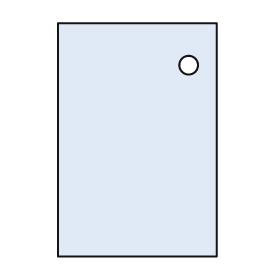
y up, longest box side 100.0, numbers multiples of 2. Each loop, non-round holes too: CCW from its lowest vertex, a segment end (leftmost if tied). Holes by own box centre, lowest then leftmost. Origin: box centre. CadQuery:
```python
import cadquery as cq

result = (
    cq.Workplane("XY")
    .moveTo(-34.0, -50.0)
    .lineTo(34.0, -50.0)
    .lineTo(34.0, 50.0)
    .lineTo(-34.0, 50.0)
    .close()
    .moveTo(22.0, 32.0)
    .circle(4.0)
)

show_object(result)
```